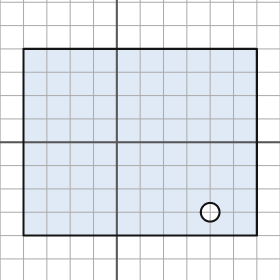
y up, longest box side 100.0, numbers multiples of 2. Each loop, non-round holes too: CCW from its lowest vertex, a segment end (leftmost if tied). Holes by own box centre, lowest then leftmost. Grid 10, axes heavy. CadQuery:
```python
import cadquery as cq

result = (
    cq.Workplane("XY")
    .moveTo(-40.0, -40.0)
    .lineTo(60.0, -40.0)
    .lineTo(60.0, 40.0)
    .lineTo(-40.0, 40.0)
    .close()
    .moveTo(40.0, -30.0)
    .circle(4.0)
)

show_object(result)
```